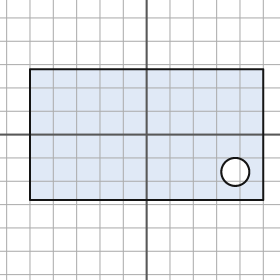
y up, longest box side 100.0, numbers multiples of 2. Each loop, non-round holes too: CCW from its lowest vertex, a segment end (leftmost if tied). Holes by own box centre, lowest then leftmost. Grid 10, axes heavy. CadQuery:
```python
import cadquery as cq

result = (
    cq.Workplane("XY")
    .moveTo(-50.0, -28.0)
    .lineTo(50.0, -28.0)
    .lineTo(50.0, 28.0)
    .lineTo(-50.0, 28.0)
    .close()
    .moveTo(38.0, -16.0)
    .circle(6.0)
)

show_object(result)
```